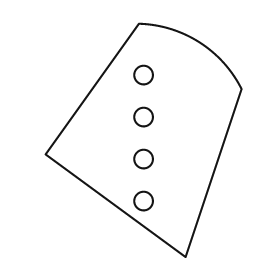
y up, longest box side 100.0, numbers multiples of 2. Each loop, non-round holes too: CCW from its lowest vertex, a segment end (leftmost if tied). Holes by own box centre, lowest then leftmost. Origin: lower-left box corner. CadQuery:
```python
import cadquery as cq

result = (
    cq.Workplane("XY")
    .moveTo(60.0, 0.0)
    .lineTo(84.0, 72.0)
    .threePointArc((66.0, 92.0), (40.0, 100.0))
    .lineTo(0.0, 44.0)
    .close()
    .moveTo(42.0, 24.0)
    .circle(4.0)
    .moveTo(42.0, 42.0)
    .circle(4.0)
    .moveTo(42.0, 60.0)
    .circle(4.0)
    .moveTo(42.0, 78.0)
    .circle(4.0)
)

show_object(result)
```